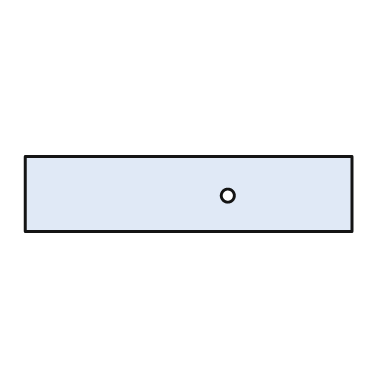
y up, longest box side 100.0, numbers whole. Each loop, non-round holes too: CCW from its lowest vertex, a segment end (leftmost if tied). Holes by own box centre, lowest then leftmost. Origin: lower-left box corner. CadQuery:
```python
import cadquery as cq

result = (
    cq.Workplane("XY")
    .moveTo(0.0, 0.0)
    .lineTo(100.0, 0.0)
    .lineTo(100.0, 23.0)
    .lineTo(0.0, 23.0)
    .close()
    .moveTo(62.0, 11.0)
    .circle(2.0)
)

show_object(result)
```